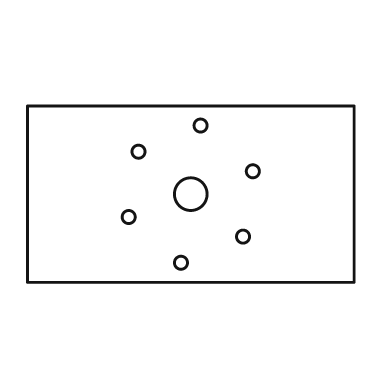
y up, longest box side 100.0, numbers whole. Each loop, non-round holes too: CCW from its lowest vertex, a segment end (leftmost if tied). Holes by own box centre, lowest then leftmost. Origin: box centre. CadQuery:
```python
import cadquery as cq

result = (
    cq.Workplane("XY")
    .moveTo(-50.0, -27.0)
    .lineTo(50.0, -27.0)
    .lineTo(50.0, 27.0)
    .lineTo(-50.0, 27.0)
    .close()
    .moveTo(-3.0, -21.0)
    .circle(2.0)
    .moveTo(16.0, -13.0)
    .circle(2.0)
    .moveTo(-19.0, -7.0)
    .circle(2.0)
    .moveTo(0.0, 0.0)
    .circle(5.0)
    .moveTo(19.0, 7.0)
    .circle(2.0)
    .moveTo(-16.0, 13.0)
    .circle(2.0)
    .moveTo(3.0, 21.0)
    .circle(2.0)
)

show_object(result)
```